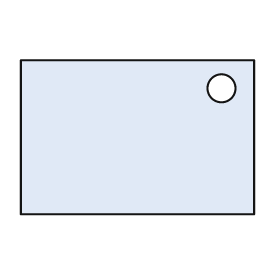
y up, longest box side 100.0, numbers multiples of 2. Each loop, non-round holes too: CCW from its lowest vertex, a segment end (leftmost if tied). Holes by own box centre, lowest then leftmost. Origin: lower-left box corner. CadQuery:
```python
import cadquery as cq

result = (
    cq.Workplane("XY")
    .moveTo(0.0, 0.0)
    .lineTo(100.0, 0.0)
    .lineTo(100.0, 66.0)
    .lineTo(0.0, 66.0)
    .close()
    .moveTo(86.0, 54.0)
    .circle(6.0)
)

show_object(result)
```